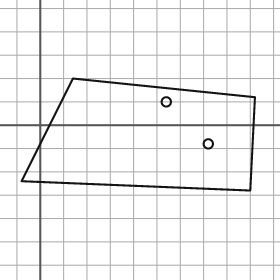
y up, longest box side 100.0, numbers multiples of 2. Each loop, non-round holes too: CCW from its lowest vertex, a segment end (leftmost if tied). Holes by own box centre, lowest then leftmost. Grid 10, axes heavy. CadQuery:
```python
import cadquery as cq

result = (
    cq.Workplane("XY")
    .moveTo(90.0, -28.0)
    .lineTo(92.0, 12.0)
    .lineTo(14.0, 20.0)
    .lineTo(-8.0, -24.0)
    .close()
    .moveTo(72.0, -8.0)
    .circle(2.0)
    .moveTo(54.0, 10.0)
    .circle(2.0)
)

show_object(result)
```